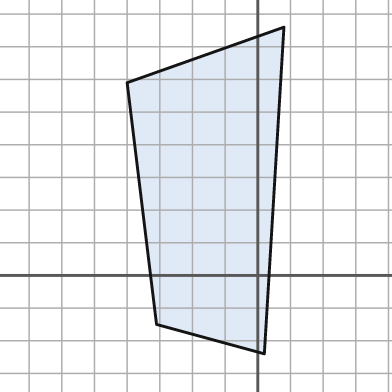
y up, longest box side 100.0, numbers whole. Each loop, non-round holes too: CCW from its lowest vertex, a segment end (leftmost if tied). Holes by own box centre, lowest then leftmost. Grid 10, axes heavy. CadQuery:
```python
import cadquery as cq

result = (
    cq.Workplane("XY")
    .moveTo(2.0, -24.0)
    .lineTo(8.0, 76.0)
    .lineTo(-40.0, 59.0)
    .lineTo(-31.0, -15.0)
    .close()
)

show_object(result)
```